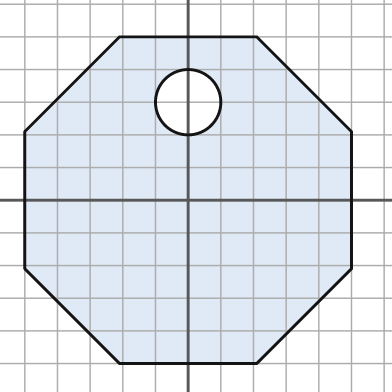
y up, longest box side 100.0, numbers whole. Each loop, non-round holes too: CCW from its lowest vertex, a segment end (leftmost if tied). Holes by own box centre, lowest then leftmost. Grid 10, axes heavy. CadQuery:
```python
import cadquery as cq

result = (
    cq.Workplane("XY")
    .moveTo(-21.0, -50.0)
    .lineTo(21.0, -50.0)
    .lineTo(50.0, -21.0)
    .lineTo(50.0, 21.0)
    .lineTo(21.0, 50.0)
    .lineTo(-21.0, 50.0)
    .lineTo(-50.0, 21.0)
    .lineTo(-50.0, -21.0)
    .close()
    .moveTo(0.0, 30.0)
    .circle(10.0)
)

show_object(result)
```